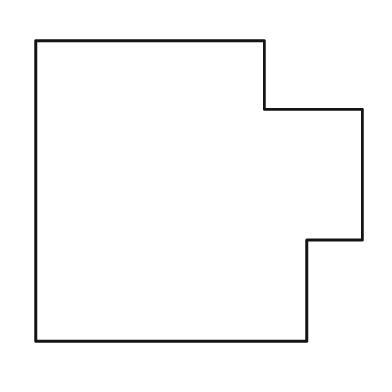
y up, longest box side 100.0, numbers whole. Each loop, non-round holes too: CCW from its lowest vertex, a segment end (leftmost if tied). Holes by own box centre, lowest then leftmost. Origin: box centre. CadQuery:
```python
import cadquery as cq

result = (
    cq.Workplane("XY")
    .moveTo(-50.0, -46.0)
    .lineTo(33.0, -46.0)
    .lineTo(33.0, -15.0)
    .lineTo(50.0, -15.0)
    .lineTo(50.0, 25.0)
    .lineTo(20.0, 25.0)
    .lineTo(20.0, 46.0)
    .lineTo(-50.0, 46.0)
    .close()
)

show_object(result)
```